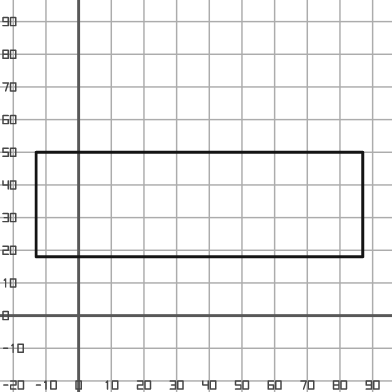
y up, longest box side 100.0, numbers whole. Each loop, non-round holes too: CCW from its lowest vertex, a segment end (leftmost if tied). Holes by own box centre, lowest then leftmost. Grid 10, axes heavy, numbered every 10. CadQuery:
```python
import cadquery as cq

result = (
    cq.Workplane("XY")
    .moveTo(-13.0, 18.0)
    .lineTo(87.0, 18.0)
    .lineTo(87.0, 50.0)
    .lineTo(-13.0, 50.0)
    .close()
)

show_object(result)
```